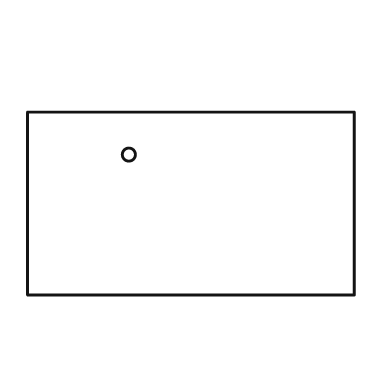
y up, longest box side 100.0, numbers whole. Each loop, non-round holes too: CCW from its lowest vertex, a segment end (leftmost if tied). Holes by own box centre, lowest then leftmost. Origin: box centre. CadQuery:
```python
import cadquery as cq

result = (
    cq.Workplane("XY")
    .moveTo(-50.0, -28.0)
    .lineTo(50.0, -28.0)
    .lineTo(50.0, 28.0)
    .lineTo(-50.0, 28.0)
    .close()
    .moveTo(-19.0, 15.0)
    .circle(2.0)
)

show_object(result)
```